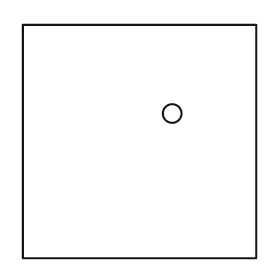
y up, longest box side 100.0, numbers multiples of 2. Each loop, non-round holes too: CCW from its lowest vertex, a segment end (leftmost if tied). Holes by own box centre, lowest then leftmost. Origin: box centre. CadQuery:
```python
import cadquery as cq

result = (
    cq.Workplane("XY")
    .moveTo(-50.0, -50.0)
    .lineTo(50.0, -50.0)
    .lineTo(50.0, 50.0)
    .lineTo(-50.0, 50.0)
    .close()
    .moveTo(14.0, 12.0)
    .circle(4.0)
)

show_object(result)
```